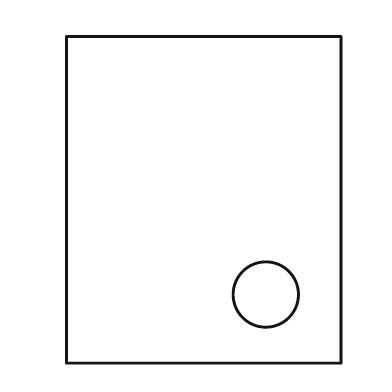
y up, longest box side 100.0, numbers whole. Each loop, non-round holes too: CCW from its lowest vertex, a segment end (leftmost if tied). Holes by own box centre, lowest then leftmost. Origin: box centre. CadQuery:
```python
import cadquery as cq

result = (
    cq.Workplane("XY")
    .moveTo(-42.0, -50.0)
    .lineTo(42.0, -50.0)
    .lineTo(42.0, 50.0)
    .lineTo(-42.0, 50.0)
    .close()
    .moveTo(19.0, -29.0)
    .circle(10.0)
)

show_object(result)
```